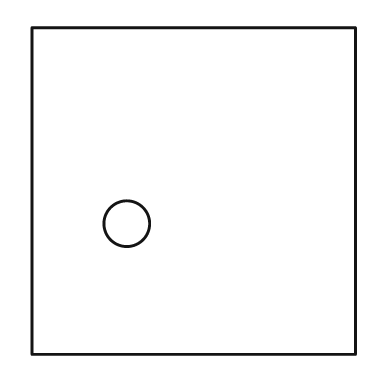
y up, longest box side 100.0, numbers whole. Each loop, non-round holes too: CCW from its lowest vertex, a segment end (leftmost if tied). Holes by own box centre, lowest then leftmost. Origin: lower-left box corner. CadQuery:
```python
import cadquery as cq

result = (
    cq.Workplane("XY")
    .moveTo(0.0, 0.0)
    .lineTo(99.0, 0.0)
    .lineTo(99.0, 100.0)
    .lineTo(0.0, 100.0)
    .close()
    .moveTo(29.0, 40.0)
    .circle(7.0)
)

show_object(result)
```